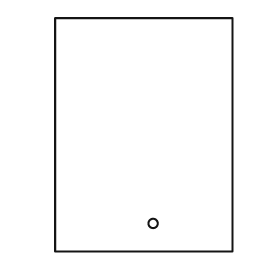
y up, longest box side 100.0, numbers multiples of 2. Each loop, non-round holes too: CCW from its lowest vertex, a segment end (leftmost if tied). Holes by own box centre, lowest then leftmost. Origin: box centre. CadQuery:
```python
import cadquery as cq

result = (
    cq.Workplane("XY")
    .moveTo(-38.0, -50.0)
    .lineTo(38.0, -50.0)
    .lineTo(38.0, 50.0)
    .lineTo(-38.0, 50.0)
    .close()
    .moveTo(4.0, -38.0)
    .circle(2.0)
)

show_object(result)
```